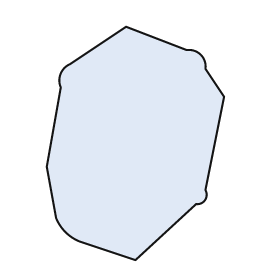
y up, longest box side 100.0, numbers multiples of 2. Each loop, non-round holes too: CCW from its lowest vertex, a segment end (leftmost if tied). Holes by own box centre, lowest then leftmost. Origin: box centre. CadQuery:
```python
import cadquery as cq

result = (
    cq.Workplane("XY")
    .moveTo(0.0, -50.0)
    .lineTo(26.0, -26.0)
    .threePointArc((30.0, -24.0), (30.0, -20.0))
    .lineTo(38.0, 20.0)
    .lineTo(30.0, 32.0)
    .threePointArc((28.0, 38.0), (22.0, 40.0))
    .lineTo(-4.0, 50.0)
    .lineTo(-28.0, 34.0)
    .threePointArc((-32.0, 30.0), (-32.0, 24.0))
    .lineTo(-38.0, -10.0)
    .lineTo(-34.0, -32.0)
    .threePointArc((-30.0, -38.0), (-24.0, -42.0))
    .close()
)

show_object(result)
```